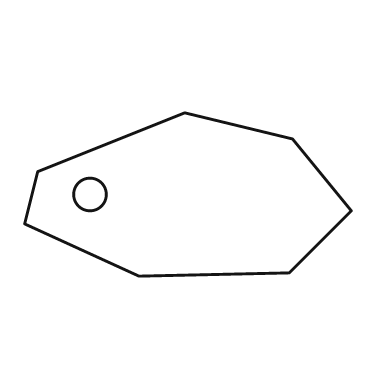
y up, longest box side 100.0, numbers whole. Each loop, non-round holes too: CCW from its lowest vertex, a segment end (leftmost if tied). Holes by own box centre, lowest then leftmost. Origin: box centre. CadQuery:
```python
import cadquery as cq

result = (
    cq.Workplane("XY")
    .moveTo(-15.0, -25.0)
    .lineTo(31.0, -24.0)
    .lineTo(50.0, -5.0)
    .lineTo(32.0, 17.0)
    .lineTo(-1.0, 25.0)
    .lineTo(-46.0, 7.0)
    .lineTo(-50.0, -9.0)
    .close()
    .moveTo(-30.0, 0.0)
    .circle(5.0)
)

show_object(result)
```